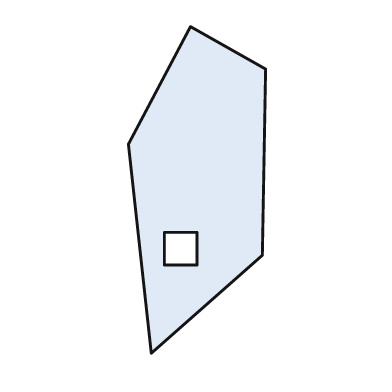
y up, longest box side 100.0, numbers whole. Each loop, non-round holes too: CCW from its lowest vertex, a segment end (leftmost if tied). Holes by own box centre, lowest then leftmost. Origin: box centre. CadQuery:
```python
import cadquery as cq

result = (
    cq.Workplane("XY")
    .moveTo(-14.0, -50.0)
    .lineTo(20.0, -20.0)
    .lineTo(21.0, 37.0)
    .lineTo(-2.0, 50.0)
    .lineTo(-21.0, 14.0)
    .close()
    .moveTo(-10.0, -23.0)
    .lineTo(0.0, -23.0)
    .lineTo(0.0, -13.0)
    .lineTo(-10.0, -13.0)
    .close()
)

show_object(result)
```